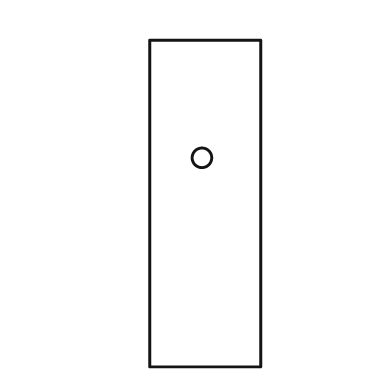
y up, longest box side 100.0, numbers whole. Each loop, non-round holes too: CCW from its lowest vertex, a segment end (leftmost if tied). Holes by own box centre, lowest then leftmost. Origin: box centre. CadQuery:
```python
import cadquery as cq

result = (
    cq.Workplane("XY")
    .moveTo(-17.0, -50.0)
    .lineTo(17.0, -50.0)
    .lineTo(17.0, 50.0)
    .lineTo(-17.0, 50.0)
    .close()
    .moveTo(-1.0, 14.0)
    .circle(3.0)
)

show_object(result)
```